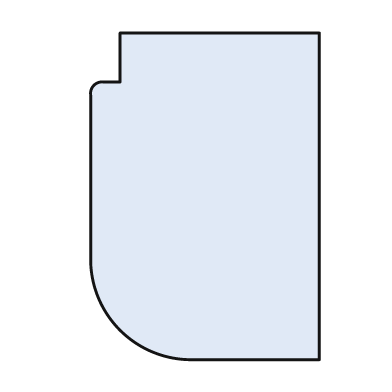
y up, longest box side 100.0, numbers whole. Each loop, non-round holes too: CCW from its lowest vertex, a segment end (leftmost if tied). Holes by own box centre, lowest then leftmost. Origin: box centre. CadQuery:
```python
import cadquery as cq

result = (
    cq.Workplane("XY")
    .moveTo(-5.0, -50.0)
    .lineTo(35.0, -50.0)
    .lineTo(35.0, 50.0)
    .lineTo(-26.0, 50.0)
    .lineTo(-26.0, 35.0)
    .lineTo(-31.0, 35.0)
    .threePointArc((-34.0, 34.0), (-35.0, 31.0))
    .lineTo(-35.0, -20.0)
    .threePointArc((-26.0, -41.0), (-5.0, -50.0))
    .close()
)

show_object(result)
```